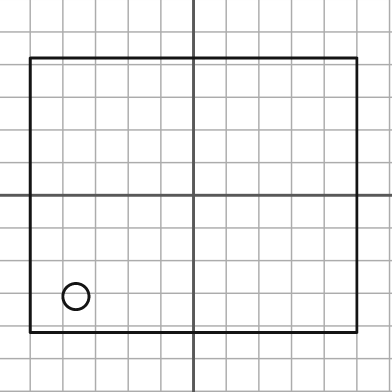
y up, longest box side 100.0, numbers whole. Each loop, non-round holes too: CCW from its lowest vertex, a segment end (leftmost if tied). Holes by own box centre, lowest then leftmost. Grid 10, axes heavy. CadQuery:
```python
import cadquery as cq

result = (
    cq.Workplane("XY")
    .moveTo(-50.0, -42.0)
    .lineTo(50.0, -42.0)
    .lineTo(50.0, 42.0)
    .lineTo(-50.0, 42.0)
    .close()
    .moveTo(-36.0, -31.0)
    .circle(4.0)
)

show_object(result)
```